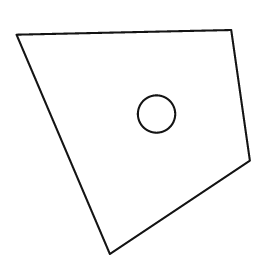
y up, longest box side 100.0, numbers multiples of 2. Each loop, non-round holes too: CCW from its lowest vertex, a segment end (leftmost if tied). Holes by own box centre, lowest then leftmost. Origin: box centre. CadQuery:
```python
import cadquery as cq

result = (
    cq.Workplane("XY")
    .moveTo(-10.0, -48.0)
    .lineTo(50.0, -8.0)
    .lineTo(42.0, 48.0)
    .lineTo(-50.0, 46.0)
    .close()
    .moveTo(10.0, 12.0)
    .circle(8.0)
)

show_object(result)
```